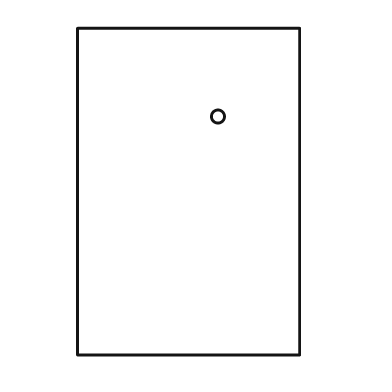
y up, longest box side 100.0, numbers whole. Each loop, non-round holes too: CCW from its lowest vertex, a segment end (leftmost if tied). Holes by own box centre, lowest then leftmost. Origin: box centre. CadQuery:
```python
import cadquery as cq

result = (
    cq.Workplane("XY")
    .moveTo(-34.0, -50.0)
    .lineTo(34.0, -50.0)
    .lineTo(34.0, 50.0)
    .lineTo(-34.0, 50.0)
    .close()
    .moveTo(9.0, 23.0)
    .circle(2.0)
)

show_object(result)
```